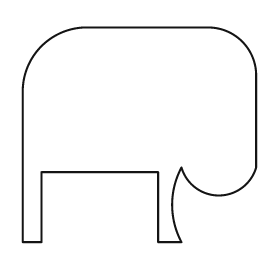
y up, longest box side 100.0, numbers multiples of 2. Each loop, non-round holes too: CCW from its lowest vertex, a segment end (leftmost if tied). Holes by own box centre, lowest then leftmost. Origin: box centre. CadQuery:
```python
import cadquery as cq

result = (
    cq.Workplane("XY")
    .moveTo(-50.0, -46.0)
    .lineTo(-42.0, -46.0)
    .lineTo(-42.0, -16.0)
    .lineTo(8.0, -16.0)
    .lineTo(8.0, -46.0)
    .lineTo(18.0, -46.0)
    .threePointArc((14.0, -30.0), (18.0, -14.0))
    .threePointArc((34.0, -26.0), (50.0, -14.0))
    .lineTo(50.0, 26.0)
    .threePointArc((44.0, 40.0), (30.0, 46.0))
    .lineTo(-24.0, 46.0)
    .threePointArc((-42.0, 38.0), (-50.0, 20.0))
    .close()
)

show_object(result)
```